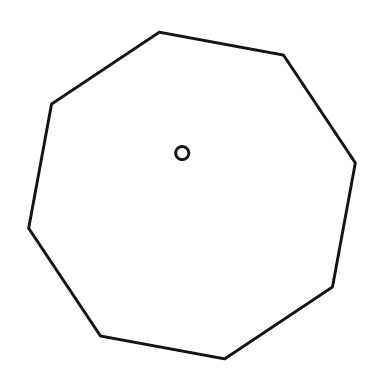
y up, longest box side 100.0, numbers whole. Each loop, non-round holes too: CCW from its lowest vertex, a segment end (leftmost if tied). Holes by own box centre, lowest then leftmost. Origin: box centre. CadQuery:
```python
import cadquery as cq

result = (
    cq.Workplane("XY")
    .moveTo(10.0, -50.0)
    .lineTo(43.0, -28.0)
    .lineTo(50.0, 10.0)
    .lineTo(28.0, 43.0)
    .lineTo(-10.0, 50.0)
    .lineTo(-43.0, 28.0)
    .lineTo(-50.0, -10.0)
    .lineTo(-28.0, -43.0)
    .close()
    .moveTo(-3.0, 13.0)
    .circle(2.0)
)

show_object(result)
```